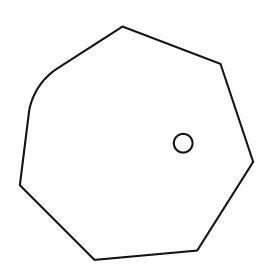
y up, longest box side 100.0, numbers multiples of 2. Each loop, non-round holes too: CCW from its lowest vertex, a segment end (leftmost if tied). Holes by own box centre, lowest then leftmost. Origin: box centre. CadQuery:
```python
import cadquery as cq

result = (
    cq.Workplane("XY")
    .moveTo(-18.0, -50.0)
    .lineTo(26.0, -46.0)
    .lineTo(50.0, -8.0)
    .lineTo(36.0, 34.0)
    .lineTo(-6.0, 50.0)
    .lineTo(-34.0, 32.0)
    .threePointArc((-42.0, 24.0), (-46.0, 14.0))
    .lineTo(-50.0, -18.0)
    .close()
    .moveTo(20.0, 0.0)
    .circle(4.0)
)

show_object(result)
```